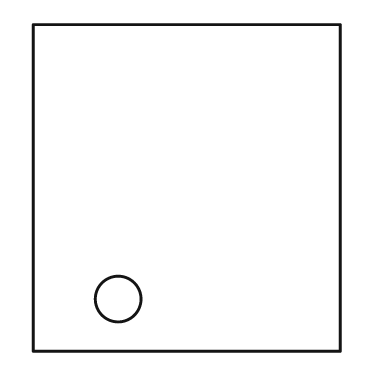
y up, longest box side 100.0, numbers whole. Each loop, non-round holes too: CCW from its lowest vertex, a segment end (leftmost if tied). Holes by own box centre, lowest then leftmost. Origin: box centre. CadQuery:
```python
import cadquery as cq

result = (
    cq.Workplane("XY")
    .moveTo(-47.0, -50.0)
    .lineTo(47.0, -50.0)
    .lineTo(47.0, 50.0)
    .lineTo(-47.0, 50.0)
    .close()
    .moveTo(-21.0, -34.0)
    .circle(7.0)
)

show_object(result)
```